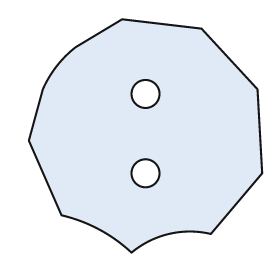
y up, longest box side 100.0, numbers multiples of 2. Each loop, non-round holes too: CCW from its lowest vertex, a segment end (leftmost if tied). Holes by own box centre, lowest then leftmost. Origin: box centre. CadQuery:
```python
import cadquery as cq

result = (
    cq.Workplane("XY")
    .moveTo(-6.0, -50.0)
    .threePointArc((10.0, -42.0), (28.0, -42.0))
    .lineTo(50.0, -16.0)
    .lineTo(48.0, 20.0)
    .lineTo(24.0, 46.0)
    .lineTo(-10.0, 50.0)
    .lineTo(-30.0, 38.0)
    .threePointArc((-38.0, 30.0), (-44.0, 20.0))
    .lineTo(-50.0, -2.0)
    .lineTo(-36.0, -34.0)
    .threePointArc((-20.0, -40.0), (-6.0, -50.0))
    .close()
    .moveTo(0.0, -16.0)
    .circle(6.0)
    .moveTo(0.0, 18.0)
    .circle(6.0)
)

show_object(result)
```